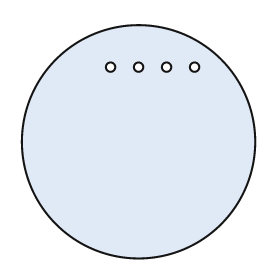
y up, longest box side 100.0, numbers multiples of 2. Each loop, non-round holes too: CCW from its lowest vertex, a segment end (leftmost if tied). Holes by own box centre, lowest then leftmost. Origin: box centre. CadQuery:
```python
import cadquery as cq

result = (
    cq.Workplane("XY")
    .moveTo(0.0, 0.0)
    .circle(50.0)
    .moveTo(-12.0, 32.0)
    .circle(2.0)
    .moveTo(0.0, 32.0)
    .circle(2.0)
    .moveTo(12.0, 32.0)
    .circle(2.0)
    .moveTo(24.0, 32.0)
    .circle(2.0)
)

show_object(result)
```